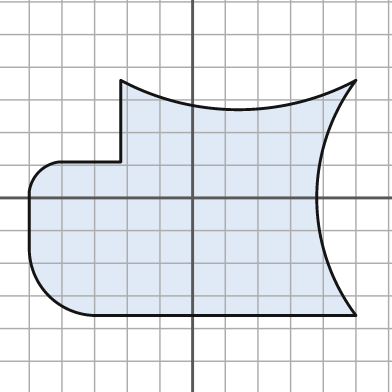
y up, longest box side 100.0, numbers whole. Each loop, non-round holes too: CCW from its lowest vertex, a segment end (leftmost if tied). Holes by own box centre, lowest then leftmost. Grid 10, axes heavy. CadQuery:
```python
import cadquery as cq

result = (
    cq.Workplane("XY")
    .moveTo(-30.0, -36.0)
    .lineTo(50.0, -36.0)
    .threePointArc((38.0, 0.0), (50.0, 36.0))
    .threePointArc((14.0, 27.0), (-22.0, 36.0))
    .lineTo(-22.0, 11.0)
    .lineTo(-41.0, 11.0)
    .threePointArc((-47.0, 8.0), (-50.0, 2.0))
    .lineTo(-50.0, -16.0)
    .threePointArc((-44.0, -30.0), (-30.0, -36.0))
    .close()
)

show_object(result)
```